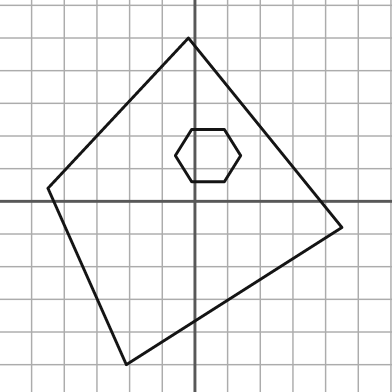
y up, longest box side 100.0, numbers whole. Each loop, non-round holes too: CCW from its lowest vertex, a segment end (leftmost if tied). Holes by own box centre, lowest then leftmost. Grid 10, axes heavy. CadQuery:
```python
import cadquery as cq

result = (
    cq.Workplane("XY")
    .moveTo(-21.0, -50.0)
    .lineTo(45.0, -8.0)
    .lineTo(-2.0, 50.0)
    .lineTo(-45.0, 4.0)
    .close()
    .moveTo(-1.0, 6.0)
    .lineTo(9.0, 6.0)
    .lineTo(14.0, 14.0)
    .lineTo(9.0, 22.0)
    .lineTo(-1.0, 22.0)
    .lineTo(-6.0, 14.0)
    .close()
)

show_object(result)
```